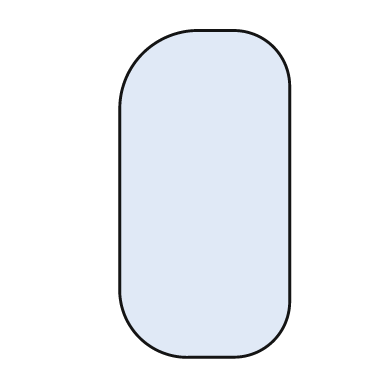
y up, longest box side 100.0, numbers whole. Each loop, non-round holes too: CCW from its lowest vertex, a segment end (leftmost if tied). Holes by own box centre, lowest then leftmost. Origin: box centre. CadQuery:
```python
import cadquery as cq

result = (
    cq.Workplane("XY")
    .moveTo(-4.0, -50.0)
    .lineTo(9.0, -50.0)
    .threePointArc((21.0, -45.0), (26.0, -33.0))
    .lineTo(26.0, 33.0)
    .threePointArc((21.0, 45.0), (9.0, 50.0))
    .lineTo(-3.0, 50.0)
    .threePointArc((-19.0, 43.0), (-26.0, 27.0))
    .lineTo(-26.0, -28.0)
    .threePointArc((-20.0, -44.0), (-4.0, -50.0))
    .close()
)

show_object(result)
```